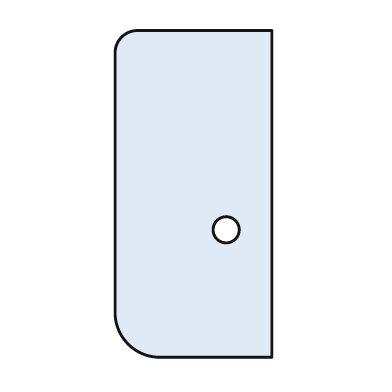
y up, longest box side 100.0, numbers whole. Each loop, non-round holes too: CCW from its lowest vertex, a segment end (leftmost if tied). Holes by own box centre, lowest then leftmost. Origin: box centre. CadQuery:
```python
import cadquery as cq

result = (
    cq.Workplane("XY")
    .moveTo(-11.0, -50.0)
    .lineTo(24.0, -50.0)
    .lineTo(24.0, 50.0)
    .lineTo(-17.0, 50.0)
    .threePointArc((-22.0, 48.0), (-24.0, 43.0))
    .lineTo(-24.0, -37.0)
    .threePointArc((-20.0, -46.0), (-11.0, -50.0))
    .close()
    .moveTo(10.0, -11.0)
    .circle(4.0)
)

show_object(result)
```